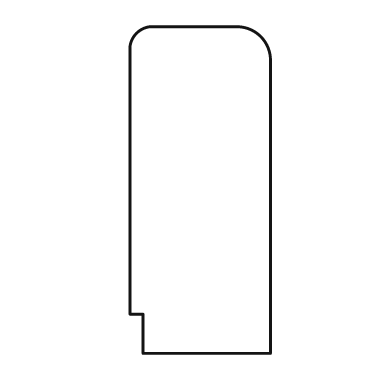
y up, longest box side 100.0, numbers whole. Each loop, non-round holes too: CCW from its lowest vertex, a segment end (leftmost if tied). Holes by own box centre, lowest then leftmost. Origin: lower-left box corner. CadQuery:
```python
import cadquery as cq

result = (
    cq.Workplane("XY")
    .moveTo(4.0, 0.0)
    .lineTo(43.0, 0.0)
    .lineTo(43.0, 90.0)
    .threePointArc((40.0, 97.0), (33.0, 100.0))
    .lineTo(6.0, 100.0)
    .threePointArc((2.0, 98.0), (0.0, 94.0))
    .lineTo(0.0, 12.0)
    .lineTo(4.0, 12.0)
    .close()
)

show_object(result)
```